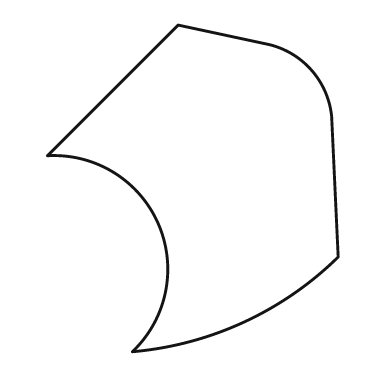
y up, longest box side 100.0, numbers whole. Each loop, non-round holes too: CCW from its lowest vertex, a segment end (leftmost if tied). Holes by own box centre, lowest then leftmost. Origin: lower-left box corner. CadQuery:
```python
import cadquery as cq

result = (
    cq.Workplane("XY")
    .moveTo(26.0, 0.0)
    .threePointArc((60.0, 9.0), (89.0, 29.0))
    .lineTo(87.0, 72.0)
    .threePointArc((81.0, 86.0), (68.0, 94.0))
    .lineTo(40.0, 100.0)
    .lineTo(0.0, 60.0)
    .threePointArc((34.0, 39.0), (26.0, 0.0))
    .close()
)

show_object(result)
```